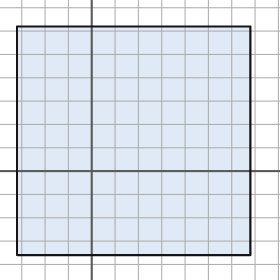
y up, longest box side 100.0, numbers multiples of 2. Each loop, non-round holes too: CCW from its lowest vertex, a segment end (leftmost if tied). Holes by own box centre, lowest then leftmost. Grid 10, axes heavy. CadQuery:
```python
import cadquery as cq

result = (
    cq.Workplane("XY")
    .moveTo(-32.0, -36.0)
    .lineTo(68.0, -36.0)
    .lineTo(68.0, 62.0)
    .lineTo(-32.0, 62.0)
    .close()
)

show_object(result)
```